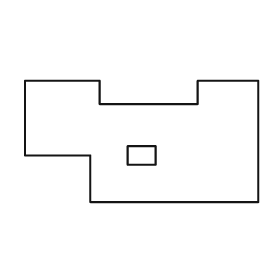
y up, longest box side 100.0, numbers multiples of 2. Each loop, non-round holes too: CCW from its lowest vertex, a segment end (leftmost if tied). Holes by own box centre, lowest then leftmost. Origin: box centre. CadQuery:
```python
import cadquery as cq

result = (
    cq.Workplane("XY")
    .moveTo(-22.0, -26.0)
    .lineTo(50.0, -26.0)
    .lineTo(50.0, 26.0)
    .lineTo(24.0, 26.0)
    .lineTo(24.0, 16.0)
    .lineTo(-18.0, 16.0)
    .lineTo(-18.0, 26.0)
    .lineTo(-50.0, 26.0)
    .lineTo(-50.0, -6.0)
    .lineTo(-22.0, -6.0)
    .close()
    .moveTo(-6.0, -10.0)
    .lineTo(6.0, -10.0)
    .lineTo(6.0, -2.0)
    .lineTo(-6.0, -2.0)
    .close()
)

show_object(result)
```